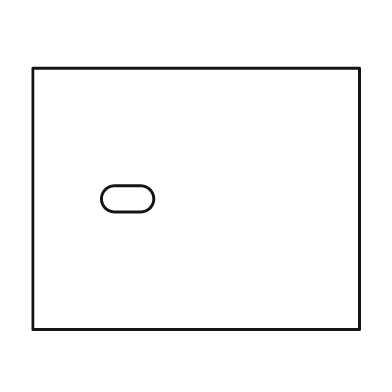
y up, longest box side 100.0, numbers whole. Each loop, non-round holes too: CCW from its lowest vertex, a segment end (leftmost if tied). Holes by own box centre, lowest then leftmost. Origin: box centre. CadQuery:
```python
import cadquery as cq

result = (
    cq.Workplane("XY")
    .moveTo(-50.0, -40.0)
    .lineTo(50.0, -40.0)
    .lineTo(50.0, 40.0)
    .lineTo(-50.0, 40.0)
    .close()
    .moveTo(-25.0, -4.0)
    .lineTo(-17.0, -4.0)
    .threePointArc((-13.0, 0.0), (-17.0, 4.0))
    .lineTo(-25.0, 4.0)
    .threePointArc((-29.0, 0.0), (-25.0, -4.0))
    .close()
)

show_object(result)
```